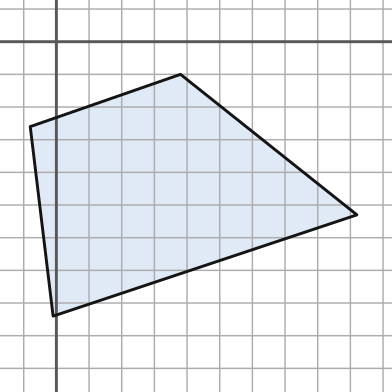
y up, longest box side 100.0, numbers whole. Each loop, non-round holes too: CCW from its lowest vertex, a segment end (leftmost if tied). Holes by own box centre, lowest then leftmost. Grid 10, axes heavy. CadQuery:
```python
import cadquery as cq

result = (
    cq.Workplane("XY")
    .moveTo(-1.0, -84.0)
    .lineTo(92.0, -53.0)
    .lineTo(38.0, -10.0)
    .lineTo(-8.0, -26.0)
    .close()
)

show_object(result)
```